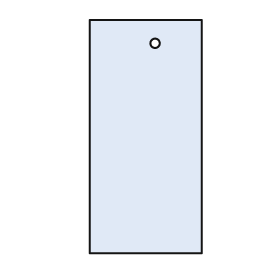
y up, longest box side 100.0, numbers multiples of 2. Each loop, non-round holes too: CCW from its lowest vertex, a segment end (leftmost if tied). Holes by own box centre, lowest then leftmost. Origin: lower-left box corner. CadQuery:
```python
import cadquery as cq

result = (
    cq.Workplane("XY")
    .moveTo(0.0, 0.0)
    .lineTo(48.0, 0.0)
    .lineTo(48.0, 100.0)
    .lineTo(0.0, 100.0)
    .close()
    .moveTo(28.0, 90.0)
    .circle(2.0)
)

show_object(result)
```